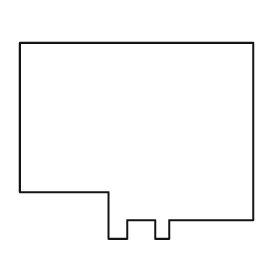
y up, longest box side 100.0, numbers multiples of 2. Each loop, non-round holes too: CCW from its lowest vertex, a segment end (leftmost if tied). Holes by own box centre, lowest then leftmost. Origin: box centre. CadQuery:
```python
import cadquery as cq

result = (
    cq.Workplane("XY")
    .moveTo(-12.0, -42.0)
    .lineTo(-4.0, -42.0)
    .lineTo(-4.0, -34.0)
    .lineTo(8.0, -34.0)
    .lineTo(8.0, -42.0)
    .lineTo(14.0, -42.0)
    .lineTo(14.0, -34.0)
    .lineTo(50.0, -34.0)
    .lineTo(50.0, 42.0)
    .lineTo(-50.0, 42.0)
    .lineTo(-50.0, -22.0)
    .lineTo(-12.0, -22.0)
    .close()
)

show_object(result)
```